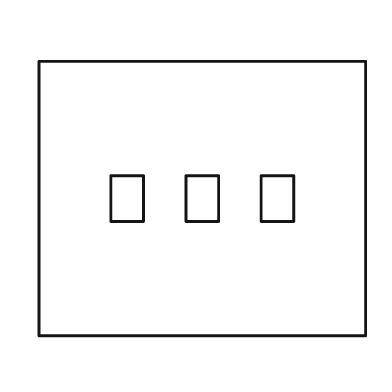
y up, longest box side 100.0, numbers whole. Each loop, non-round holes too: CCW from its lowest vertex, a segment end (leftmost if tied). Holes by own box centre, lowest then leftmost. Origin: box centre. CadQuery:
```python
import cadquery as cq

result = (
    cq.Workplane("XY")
    .moveTo(-50.0, -42.0)
    .lineTo(50.0, -42.0)
    .lineTo(50.0, 42.0)
    .lineTo(-50.0, 42.0)
    .close()
    .moveTo(-28.0, -7.0)
    .lineTo(-18.0, -7.0)
    .lineTo(-18.0, 7.0)
    .lineTo(-28.0, 7.0)
    .close()
    .moveTo(-5.0, -7.0)
    .lineTo(5.0, -7.0)
    .lineTo(5.0, 7.0)
    .lineTo(-5.0, 7.0)
    .close()
    .moveTo(18.0, -7.0)
    .lineTo(28.0, -7.0)
    .lineTo(28.0, 7.0)
    .lineTo(18.0, 7.0)
    .close()
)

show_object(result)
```